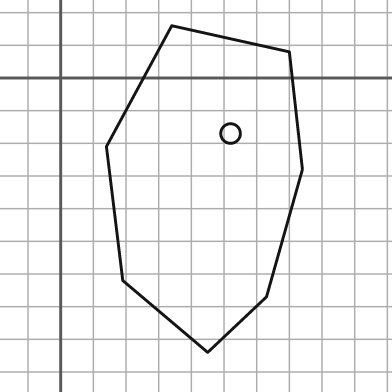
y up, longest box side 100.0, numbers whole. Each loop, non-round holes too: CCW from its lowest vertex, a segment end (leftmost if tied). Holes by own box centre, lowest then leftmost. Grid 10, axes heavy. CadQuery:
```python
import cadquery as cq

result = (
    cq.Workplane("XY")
    .moveTo(45.0, -84.0)
    .lineTo(63.0, -67.0)
    .lineTo(74.0, -28.0)
    .lineTo(70.0, 8.0)
    .lineTo(34.0, 16.0)
    .lineTo(14.0, -21.0)
    .lineTo(19.0, -62.0)
    .close()
    .moveTo(52.0, -17.0)
    .circle(3.0)
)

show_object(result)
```